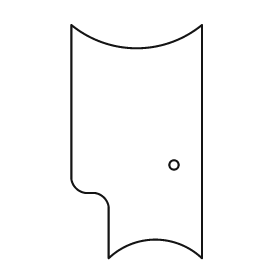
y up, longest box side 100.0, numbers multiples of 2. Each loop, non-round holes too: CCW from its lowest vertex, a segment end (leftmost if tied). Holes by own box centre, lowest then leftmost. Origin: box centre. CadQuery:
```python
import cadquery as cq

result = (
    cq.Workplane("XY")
    .moveTo(-12.0, -50.0)
    .threePointArc((8.0, -42.0), (28.0, -50.0))
    .lineTo(28.0, 50.0)
    .threePointArc((0.0, 40.0), (-28.0, 50.0))
    .lineTo(-28.0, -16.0)
    .threePointArc((-26.0, -20.0), (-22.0, -22.0))
    .lineTo(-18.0, -22.0)
    .threePointArc((-14.0, -24.0), (-12.0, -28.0))
    .close()
    .moveTo(16.0, -10.0)
    .circle(2.0)
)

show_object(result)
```